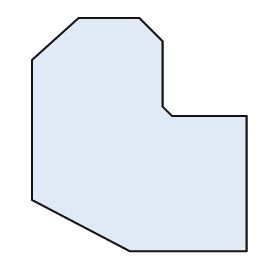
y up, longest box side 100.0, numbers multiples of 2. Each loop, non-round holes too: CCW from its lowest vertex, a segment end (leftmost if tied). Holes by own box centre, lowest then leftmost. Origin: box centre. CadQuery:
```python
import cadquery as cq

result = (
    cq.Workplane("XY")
    .moveTo(-4.0, -50.0)
    .lineTo(46.0, -50.0)
    .lineTo(46.0, 8.0)
    .lineTo(14.0, 8.0)
    .lineTo(10.0, 12.0)
    .lineTo(10.0, 40.0)
    .lineTo(0.0, 50.0)
    .lineTo(-26.0, 50.0)
    .lineTo(-46.0, 32.0)
    .lineTo(-46.0, -28.0)
    .close()
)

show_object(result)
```